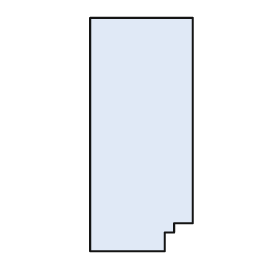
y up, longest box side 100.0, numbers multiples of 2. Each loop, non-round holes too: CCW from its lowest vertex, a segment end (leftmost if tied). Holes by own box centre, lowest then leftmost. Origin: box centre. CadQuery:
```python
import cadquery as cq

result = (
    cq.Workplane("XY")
    .moveTo(-22.0, -50.0)
    .lineTo(10.0, -50.0)
    .lineTo(10.0, -42.0)
    .lineTo(14.0, -42.0)
    .lineTo(14.0, -38.0)
    .lineTo(22.0, -38.0)
    .lineTo(22.0, 50.0)
    .lineTo(-22.0, 50.0)
    .close()
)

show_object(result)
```